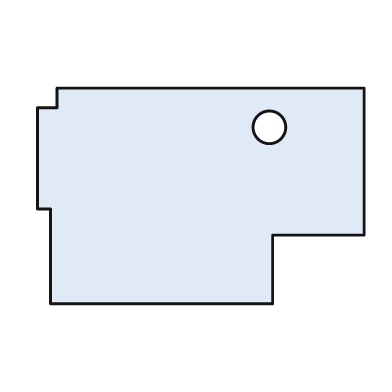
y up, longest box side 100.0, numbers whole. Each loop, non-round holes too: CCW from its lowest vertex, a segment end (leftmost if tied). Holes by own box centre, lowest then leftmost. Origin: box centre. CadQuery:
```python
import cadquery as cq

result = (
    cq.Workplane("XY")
    .moveTo(-46.0, -33.0)
    .lineTo(22.0, -33.0)
    .lineTo(22.0, -12.0)
    .lineTo(50.0, -12.0)
    .lineTo(50.0, 33.0)
    .lineTo(-44.0, 33.0)
    .lineTo(-44.0, 27.0)
    .lineTo(-50.0, 27.0)
    .lineTo(-50.0, -4.0)
    .lineTo(-46.0, -4.0)
    .close()
    .moveTo(21.0, 21.0)
    .circle(5.0)
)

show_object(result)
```